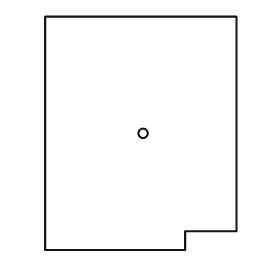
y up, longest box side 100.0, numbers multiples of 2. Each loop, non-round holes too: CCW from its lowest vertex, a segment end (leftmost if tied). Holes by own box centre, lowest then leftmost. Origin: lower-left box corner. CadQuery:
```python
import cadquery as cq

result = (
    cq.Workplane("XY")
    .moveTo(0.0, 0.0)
    .lineTo(60.0, 0.0)
    .lineTo(60.0, 8.0)
    .lineTo(82.0, 8.0)
    .lineTo(82.0, 100.0)
    .lineTo(0.0, 100.0)
    .close()
    .moveTo(42.0, 50.0)
    .circle(2.0)
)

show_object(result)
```